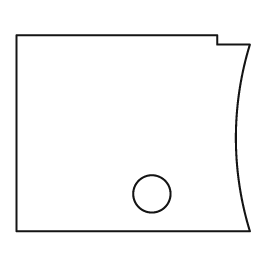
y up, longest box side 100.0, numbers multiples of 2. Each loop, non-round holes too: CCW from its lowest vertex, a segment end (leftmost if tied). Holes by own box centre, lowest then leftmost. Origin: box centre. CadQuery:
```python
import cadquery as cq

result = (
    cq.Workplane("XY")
    .moveTo(-50.0, -42.0)
    .lineTo(50.0, -42.0)
    .threePointArc((44.0, -2.0), (50.0, 38.0))
    .lineTo(36.0, 38.0)
    .lineTo(36.0, 42.0)
    .lineTo(-50.0, 42.0)
    .close()
    .moveTo(8.0, -26.0)
    .circle(8.0)
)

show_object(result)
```